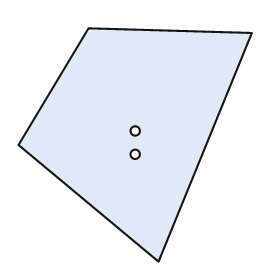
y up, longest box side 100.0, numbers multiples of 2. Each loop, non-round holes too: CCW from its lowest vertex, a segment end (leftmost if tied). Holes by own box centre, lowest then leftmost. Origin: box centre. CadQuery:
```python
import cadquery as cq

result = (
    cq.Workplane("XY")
    .moveTo(10.0, -50.0)
    .lineTo(50.0, 48.0)
    .lineTo(-20.0, 50.0)
    .lineTo(-50.0, 0.0)
    .close()
    .moveTo(0.0, -4.0)
    .circle(2.0)
    .moveTo(0.0, 6.0)
    .circle(2.0)
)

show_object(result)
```